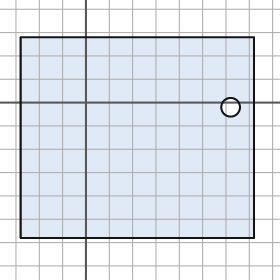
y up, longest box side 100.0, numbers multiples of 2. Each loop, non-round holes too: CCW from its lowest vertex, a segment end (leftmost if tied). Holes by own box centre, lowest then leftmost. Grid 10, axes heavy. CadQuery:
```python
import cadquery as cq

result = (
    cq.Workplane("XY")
    .moveTo(-28.0, -58.0)
    .lineTo(72.0, -58.0)
    .lineTo(72.0, 28.0)
    .lineTo(-28.0, 28.0)
    .close()
    .moveTo(62.0, -2.0)
    .circle(4.0)
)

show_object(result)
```